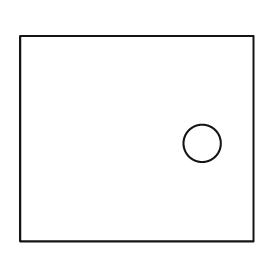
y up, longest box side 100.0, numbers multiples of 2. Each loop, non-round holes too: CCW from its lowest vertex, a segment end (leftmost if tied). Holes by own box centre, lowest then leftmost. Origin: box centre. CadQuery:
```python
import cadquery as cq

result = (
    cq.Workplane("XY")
    .moveTo(-50.0, -44.0)
    .lineTo(50.0, -44.0)
    .lineTo(50.0, 44.0)
    .lineTo(-50.0, 44.0)
    .close()
    .moveTo(28.0, -2.0)
    .circle(8.0)
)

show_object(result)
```